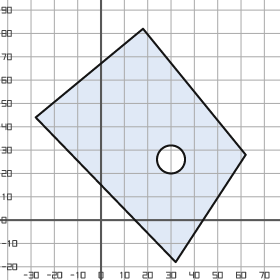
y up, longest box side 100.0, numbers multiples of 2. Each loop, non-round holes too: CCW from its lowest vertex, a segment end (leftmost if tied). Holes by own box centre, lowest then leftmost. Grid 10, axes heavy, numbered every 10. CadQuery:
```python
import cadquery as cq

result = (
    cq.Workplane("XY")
    .moveTo(32.0, -18.0)
    .lineTo(62.0, 28.0)
    .lineTo(18.0, 82.0)
    .lineTo(-28.0, 44.0)
    .close()
    .moveTo(30.0, 26.0)
    .circle(6.0)
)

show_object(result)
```